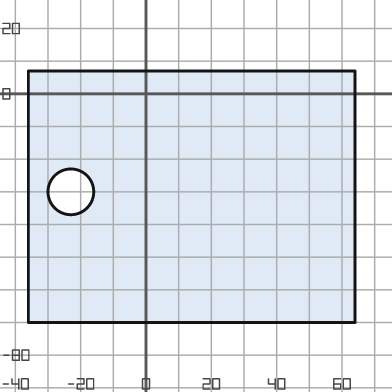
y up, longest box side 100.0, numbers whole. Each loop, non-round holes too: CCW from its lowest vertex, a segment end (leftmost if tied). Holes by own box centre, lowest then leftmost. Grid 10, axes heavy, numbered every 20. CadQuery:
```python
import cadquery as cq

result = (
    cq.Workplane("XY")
    .moveTo(-36.0, -70.0)
    .lineTo(64.0, -70.0)
    .lineTo(64.0, 7.0)
    .lineTo(-36.0, 7.0)
    .close()
    .moveTo(-23.0, -30.0)
    .circle(7.0)
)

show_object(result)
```